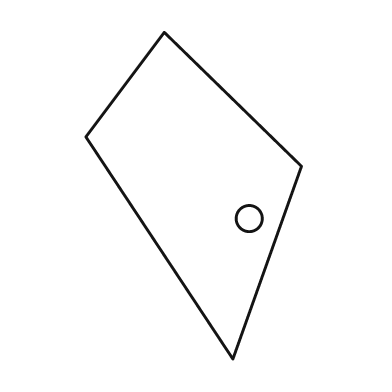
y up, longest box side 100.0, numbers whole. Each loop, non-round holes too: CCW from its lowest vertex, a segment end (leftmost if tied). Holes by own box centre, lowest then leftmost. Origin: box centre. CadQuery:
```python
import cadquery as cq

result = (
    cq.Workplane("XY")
    .moveTo(12.0, -50.0)
    .lineTo(33.0, 9.0)
    .lineTo(-9.0, 50.0)
    .lineTo(-33.0, 18.0)
    .close()
    .moveTo(17.0, -7.0)
    .circle(4.0)
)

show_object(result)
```